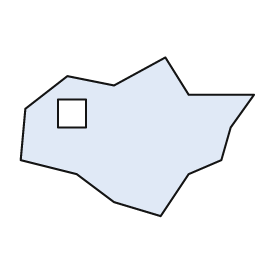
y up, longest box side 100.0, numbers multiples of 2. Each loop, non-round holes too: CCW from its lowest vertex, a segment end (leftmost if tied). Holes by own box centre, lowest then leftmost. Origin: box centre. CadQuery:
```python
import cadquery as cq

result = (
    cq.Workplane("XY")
    .moveTo(10.0, -34.0)
    .lineTo(22.0, -16.0)
    .lineTo(36.0, -10.0)
    .lineTo(40.0, 4.0)
    .lineTo(50.0, 18.0)
    .lineTo(22.0, 18.0)
    .lineTo(12.0, 34.0)
    .lineTo(-10.0, 22.0)
    .lineTo(-30.0, 26.0)
    .lineTo(-48.0, 12.0)
    .lineTo(-50.0, -10.0)
    .lineTo(-26.0, -16.0)
    .lineTo(-10.0, -28.0)
    .close()
    .moveTo(-34.0, 4.0)
    .lineTo(-22.0, 4.0)
    .lineTo(-22.0, 16.0)
    .lineTo(-34.0, 16.0)
    .close()
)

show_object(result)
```